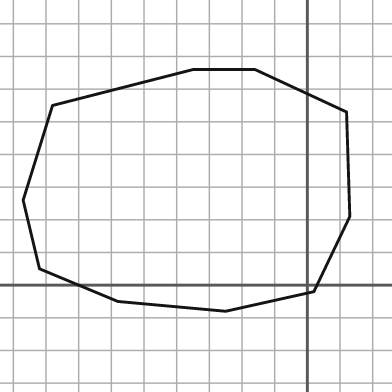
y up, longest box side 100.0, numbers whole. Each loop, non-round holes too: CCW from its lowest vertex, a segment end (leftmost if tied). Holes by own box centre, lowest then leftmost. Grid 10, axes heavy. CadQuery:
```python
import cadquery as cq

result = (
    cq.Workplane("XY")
    .moveTo(-25.0, -8.0)
    .lineTo(2.0, -2.0)
    .lineTo(13.0, 21.0)
    .lineTo(12.0, 53.0)
    .lineTo(-16.0, 66.0)
    .lineTo(-35.0, 66.0)
    .lineTo(-78.0, 55.0)
    .lineTo(-87.0, 26.0)
    .lineTo(-82.0, 5.0)
    .lineTo(-58.0, -5.0)
    .close()
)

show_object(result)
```